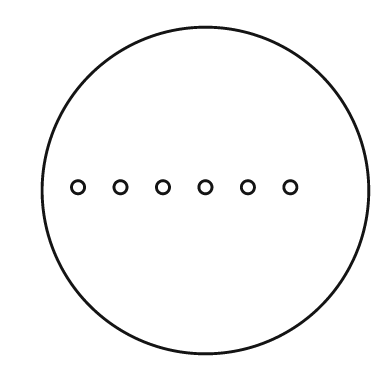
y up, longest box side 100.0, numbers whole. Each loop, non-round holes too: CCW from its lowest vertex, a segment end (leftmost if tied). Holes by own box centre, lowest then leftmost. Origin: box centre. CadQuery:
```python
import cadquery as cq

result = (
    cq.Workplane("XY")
    .moveTo(0.0, 0.0)
    .circle(50.0)
    .moveTo(-39.0, 1.0)
    .circle(2.0)
    .moveTo(-26.0, 1.0)
    .circle(2.0)
    .moveTo(-13.0, 1.0)
    .circle(2.0)
    .moveTo(0.0, 1.0)
    .circle(2.0)
    .moveTo(13.0, 1.0)
    .circle(2.0)
    .moveTo(26.0, 1.0)
    .circle(2.0)
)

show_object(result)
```